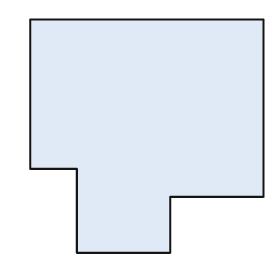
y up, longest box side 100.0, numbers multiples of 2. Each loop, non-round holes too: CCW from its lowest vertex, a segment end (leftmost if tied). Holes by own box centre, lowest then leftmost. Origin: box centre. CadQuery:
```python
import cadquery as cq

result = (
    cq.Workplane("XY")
    .moveTo(-30.0, -50.0)
    .lineTo(10.0, -50.0)
    .lineTo(10.0, -26.0)
    .lineTo(50.0, -26.0)
    .lineTo(50.0, 50.0)
    .lineTo(-50.0, 50.0)
    .lineTo(-50.0, -14.0)
    .lineTo(-30.0, -14.0)
    .close()
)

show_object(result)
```